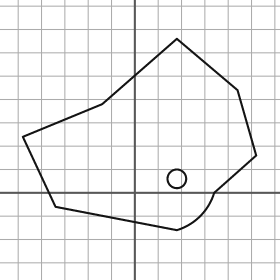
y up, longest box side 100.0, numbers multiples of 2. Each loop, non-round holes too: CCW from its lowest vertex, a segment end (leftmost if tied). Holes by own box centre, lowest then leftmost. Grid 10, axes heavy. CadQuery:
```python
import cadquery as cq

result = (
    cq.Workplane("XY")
    .moveTo(18.0, -16.0)
    .threePointArc((28.0, -10.0), (34.0, 0.0))
    .lineTo(52.0, 16.0)
    .lineTo(44.0, 44.0)
    .lineTo(18.0, 66.0)
    .lineTo(-14.0, 38.0)
    .lineTo(-48.0, 24.0)
    .lineTo(-34.0, -6.0)
    .close()
    .moveTo(18.0, 6.0)
    .circle(4.0)
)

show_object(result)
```